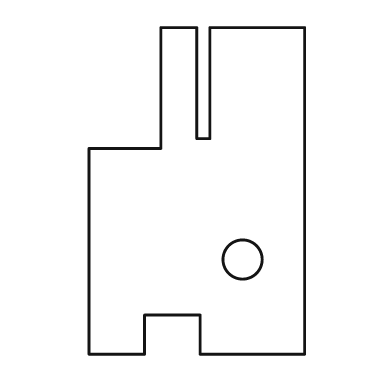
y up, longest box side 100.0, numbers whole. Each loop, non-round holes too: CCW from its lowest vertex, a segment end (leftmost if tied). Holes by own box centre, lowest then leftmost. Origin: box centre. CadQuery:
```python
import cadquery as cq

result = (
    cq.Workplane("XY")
    .moveTo(-33.0, -50.0)
    .lineTo(-16.0, -50.0)
    .lineTo(-16.0, -38.0)
    .lineTo(1.0, -38.0)
    .lineTo(1.0, -50.0)
    .lineTo(33.0, -50.0)
    .lineTo(33.0, 50.0)
    .lineTo(4.0, 50.0)
    .lineTo(4.0, 16.0)
    .lineTo(0.0, 16.0)
    .lineTo(0.0, 50.0)
    .lineTo(-11.0, 50.0)
    .lineTo(-11.0, 13.0)
    .lineTo(-33.0, 13.0)
    .close()
    .moveTo(14.0, -21.0)
    .circle(6.0)
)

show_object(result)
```